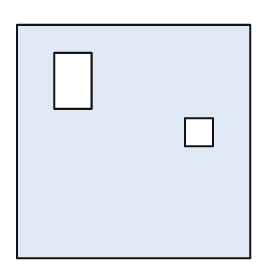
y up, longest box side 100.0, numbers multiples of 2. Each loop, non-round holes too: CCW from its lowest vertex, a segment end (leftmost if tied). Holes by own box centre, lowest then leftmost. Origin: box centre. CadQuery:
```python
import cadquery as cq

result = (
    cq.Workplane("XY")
    .moveTo(-50.0, -50.0)
    .lineTo(50.0, -50.0)
    .lineTo(50.0, 50.0)
    .lineTo(-50.0, 50.0)
    .close()
    .moveTo(22.0, -2.0)
    .lineTo(34.0, -2.0)
    .lineTo(34.0, 10.0)
    .lineTo(22.0, 10.0)
    .close()
    .moveTo(-34.0, 14.0)
    .lineTo(-18.0, 14.0)
    .lineTo(-18.0, 38.0)
    .lineTo(-34.0, 38.0)
    .close()
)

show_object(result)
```